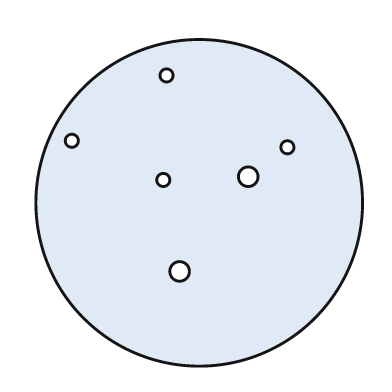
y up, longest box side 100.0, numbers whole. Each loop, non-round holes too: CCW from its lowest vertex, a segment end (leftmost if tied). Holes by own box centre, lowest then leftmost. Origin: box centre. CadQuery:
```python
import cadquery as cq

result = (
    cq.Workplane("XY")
    .moveTo(0.0, 0.0)
    .circle(50.0)
    .moveTo(-6.0, -21.0)
    .circle(3.0)
    .moveTo(-11.0, 7.0)
    .circle(2.0)
    .moveTo(15.0, 8.0)
    .circle(3.0)
    .moveTo(27.0, 17.0)
    .circle(2.0)
    .moveTo(-39.0, 19.0)
    .circle(2.0)
    .moveTo(-10.0, 39.0)
    .circle(2.0)
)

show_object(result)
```